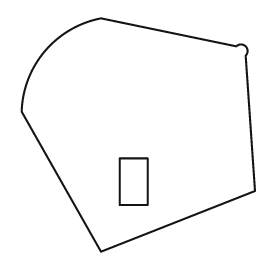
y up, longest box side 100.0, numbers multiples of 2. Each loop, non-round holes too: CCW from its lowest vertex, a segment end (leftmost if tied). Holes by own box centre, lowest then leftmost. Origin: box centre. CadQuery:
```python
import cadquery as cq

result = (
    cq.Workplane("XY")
    .moveTo(-16.0, -50.0)
    .lineTo(50.0, -24.0)
    .lineTo(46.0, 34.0)
    .threePointArc((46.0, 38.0), (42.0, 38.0))
    .lineTo(-16.0, 50.0)
    .threePointArc((-40.0, 36.0), (-50.0, 10.0))
    .close()
    .moveTo(-8.0, -30.0)
    .lineTo(4.0, -30.0)
    .lineTo(4.0, -10.0)
    .lineTo(-8.0, -10.0)
    .close()
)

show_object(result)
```